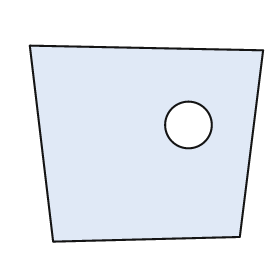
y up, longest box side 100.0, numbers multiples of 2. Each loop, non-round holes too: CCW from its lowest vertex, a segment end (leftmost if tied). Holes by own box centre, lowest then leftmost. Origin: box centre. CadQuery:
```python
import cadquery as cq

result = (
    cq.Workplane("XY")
    .moveTo(-40.0, -42.0)
    .lineTo(40.0, -40.0)
    .lineTo(50.0, 40.0)
    .lineTo(-50.0, 42.0)
    .close()
    .moveTo(18.0, 8.0)
    .circle(10.0)
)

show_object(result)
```